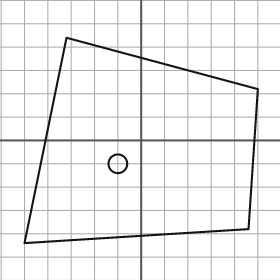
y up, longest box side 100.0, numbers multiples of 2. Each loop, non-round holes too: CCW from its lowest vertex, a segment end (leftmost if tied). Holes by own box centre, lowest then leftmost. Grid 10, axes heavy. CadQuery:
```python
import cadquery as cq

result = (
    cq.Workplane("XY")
    .moveTo(-50.0, -44.0)
    .lineTo(46.0, -38.0)
    .lineTo(50.0, 22.0)
    .lineTo(-32.0, 44.0)
    .close()
    .moveTo(-10.0, -10.0)
    .circle(4.0)
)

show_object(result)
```